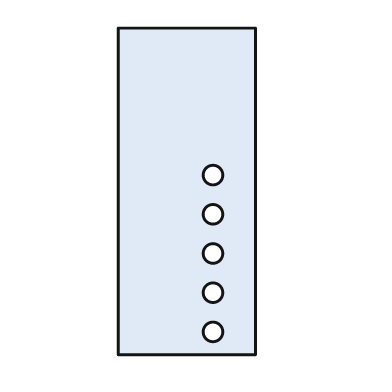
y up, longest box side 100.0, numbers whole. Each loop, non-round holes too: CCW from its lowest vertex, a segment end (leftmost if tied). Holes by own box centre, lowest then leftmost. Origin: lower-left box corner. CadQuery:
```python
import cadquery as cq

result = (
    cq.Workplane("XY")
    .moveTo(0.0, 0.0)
    .lineTo(42.0, 0.0)
    .lineTo(42.0, 100.0)
    .lineTo(0.0, 100.0)
    .close()
    .moveTo(29.0, 7.0)
    .circle(3.0)
    .moveTo(29.0, 19.0)
    .circle(3.0)
    .moveTo(29.0, 31.0)
    .circle(3.0)
    .moveTo(29.0, 43.0)
    .circle(3.0)
    .moveTo(29.0, 55.0)
    .circle(3.0)
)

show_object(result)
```